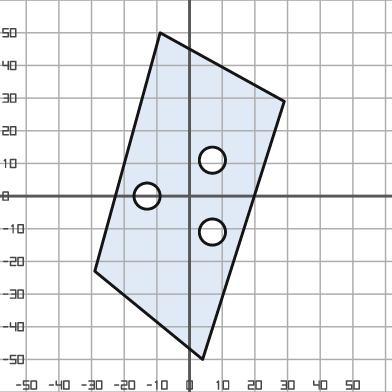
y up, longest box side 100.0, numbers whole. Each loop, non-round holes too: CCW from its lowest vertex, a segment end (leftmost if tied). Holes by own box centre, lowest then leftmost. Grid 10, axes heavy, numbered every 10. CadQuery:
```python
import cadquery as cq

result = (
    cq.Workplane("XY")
    .moveTo(4.0, -50.0)
    .lineTo(29.0, 29.0)
    .lineTo(-9.0, 50.0)
    .lineTo(-29.0, -23.0)
    .close()
    .moveTo(7.0, -11.0)
    .circle(4.0)
    .moveTo(-13.0, 0.0)
    .circle(4.0)
    .moveTo(7.0, 11.0)
    .circle(4.0)
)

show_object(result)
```